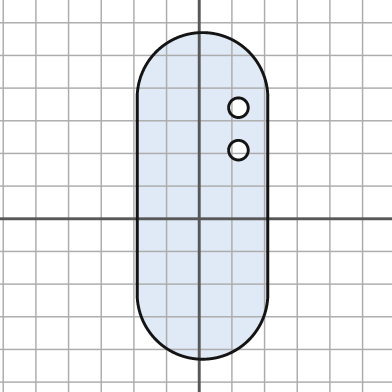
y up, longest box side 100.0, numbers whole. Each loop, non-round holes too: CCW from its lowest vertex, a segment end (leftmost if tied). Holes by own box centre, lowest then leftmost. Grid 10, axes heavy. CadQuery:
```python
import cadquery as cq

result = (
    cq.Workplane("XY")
    .moveTo(-19.0, -23.0)
    .threePointArc((1.0, -43.0), (21.0, -23.0))
    .lineTo(21.0, 37.0)
    .threePointArc((1.0, 57.0), (-19.0, 37.0))
    .close()
    .moveTo(12.0, 21.0)
    .circle(3.0)
    .moveTo(12.0, 34.0)
    .circle(3.0)
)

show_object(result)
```